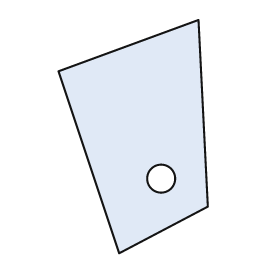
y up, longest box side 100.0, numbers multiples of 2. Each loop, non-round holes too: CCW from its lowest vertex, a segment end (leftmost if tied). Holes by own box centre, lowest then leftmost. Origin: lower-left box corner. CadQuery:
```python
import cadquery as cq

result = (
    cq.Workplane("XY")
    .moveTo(26.0, 0.0)
    .lineTo(64.0, 20.0)
    .lineTo(60.0, 100.0)
    .lineTo(0.0, 78.0)
    .close()
    .moveTo(44.0, 32.0)
    .circle(6.0)
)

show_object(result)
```